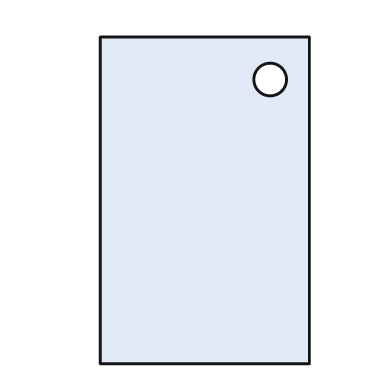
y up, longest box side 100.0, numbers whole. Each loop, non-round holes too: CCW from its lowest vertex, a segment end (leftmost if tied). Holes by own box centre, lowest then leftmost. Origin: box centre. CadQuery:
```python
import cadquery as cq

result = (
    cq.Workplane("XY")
    .moveTo(-32.0, -50.0)
    .lineTo(32.0, -50.0)
    .lineTo(32.0, 50.0)
    .lineTo(-32.0, 50.0)
    .close()
    .moveTo(20.0, 37.0)
    .circle(5.0)
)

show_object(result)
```